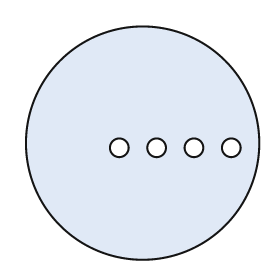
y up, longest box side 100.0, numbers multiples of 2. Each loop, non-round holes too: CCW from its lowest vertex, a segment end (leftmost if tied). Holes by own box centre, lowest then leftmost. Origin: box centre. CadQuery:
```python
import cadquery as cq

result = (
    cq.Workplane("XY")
    .moveTo(0.0, 0.0)
    .circle(50.0)
    .moveTo(-10.0, -2.0)
    .circle(4.0)
    .moveTo(6.0, -2.0)
    .circle(4.0)
    .moveTo(22.0, -2.0)
    .circle(4.0)
    .moveTo(38.0, -2.0)
    .circle(4.0)
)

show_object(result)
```